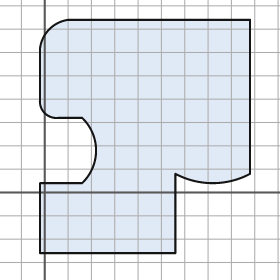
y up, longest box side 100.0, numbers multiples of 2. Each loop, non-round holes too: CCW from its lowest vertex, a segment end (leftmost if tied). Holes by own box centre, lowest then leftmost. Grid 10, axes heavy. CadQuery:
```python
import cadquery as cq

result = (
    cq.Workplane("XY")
    .moveTo(-2.0, -26.0)
    .lineTo(56.0, -26.0)
    .lineTo(56.0, 8.0)
    .threePointArc((72.0, 4.0), (88.0, 8.0))
    .lineTo(88.0, 74.0)
    .lineTo(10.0, 74.0)
    .threePointArc((2.0, 70.0), (-2.0, 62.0))
    .lineTo(-2.0, 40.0)
    .threePointArc((0.0, 34.0), (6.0, 32.0))
    .lineTo(16.0, 32.0)
    .threePointArc((22.0, 18.0), (16.0, 4.0))
    .lineTo(-2.0, 4.0)
    .close()
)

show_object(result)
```